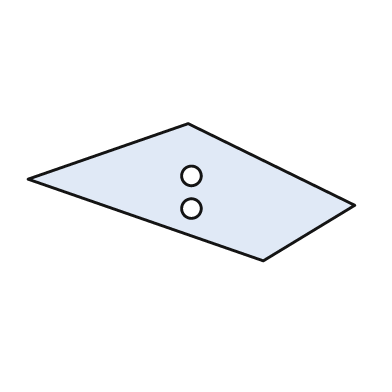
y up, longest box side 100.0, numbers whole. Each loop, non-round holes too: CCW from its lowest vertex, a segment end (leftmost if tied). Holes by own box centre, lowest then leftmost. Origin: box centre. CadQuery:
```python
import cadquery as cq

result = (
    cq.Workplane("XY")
    .moveTo(22.0, -21.0)
    .lineTo(50.0, -4.0)
    .lineTo(-1.0, 21.0)
    .lineTo(-50.0, 4.0)
    .close()
    .moveTo(0.0, -5.0)
    .circle(3.0)
    .moveTo(0.0, 5.0)
    .circle(3.0)
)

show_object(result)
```